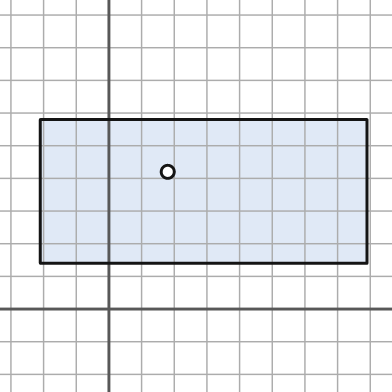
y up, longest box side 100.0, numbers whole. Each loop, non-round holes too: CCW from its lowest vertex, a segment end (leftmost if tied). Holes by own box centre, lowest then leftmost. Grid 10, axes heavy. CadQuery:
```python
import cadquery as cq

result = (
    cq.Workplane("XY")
    .moveTo(-21.0, 14.0)
    .lineTo(79.0, 14.0)
    .lineTo(79.0, 58.0)
    .lineTo(-21.0, 58.0)
    .close()
    .moveTo(18.0, 42.0)
    .circle(2.0)
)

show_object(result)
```